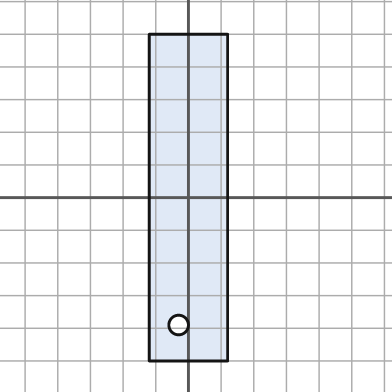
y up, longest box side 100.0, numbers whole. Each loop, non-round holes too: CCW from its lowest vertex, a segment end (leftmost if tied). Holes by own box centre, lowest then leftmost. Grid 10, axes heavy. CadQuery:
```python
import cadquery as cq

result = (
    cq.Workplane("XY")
    .moveTo(-12.0, -50.0)
    .lineTo(12.0, -50.0)
    .lineTo(12.0, 50.0)
    .lineTo(-12.0, 50.0)
    .close()
    .moveTo(-3.0, -39.0)
    .circle(3.0)
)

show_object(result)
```